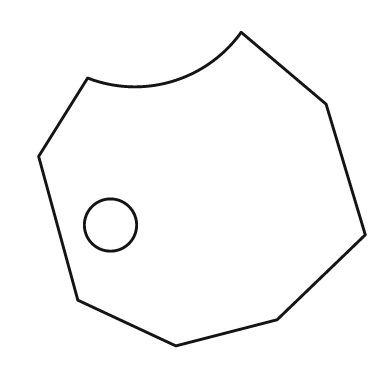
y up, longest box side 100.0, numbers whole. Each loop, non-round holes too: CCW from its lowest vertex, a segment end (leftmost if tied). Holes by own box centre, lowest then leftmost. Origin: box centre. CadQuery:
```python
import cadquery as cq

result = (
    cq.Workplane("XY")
    .moveTo(-8.0, -48.0)
    .lineTo(23.0, -40.0)
    .lineTo(50.0, -14.0)
    .lineTo(38.0, 26.0)
    .lineTo(12.0, 48.0)
    .threePointArc((-9.0, 33.0), (-35.0, 34.0))
    .lineTo(-50.0, 10.0)
    .lineTo(-38.0, -34.0)
    .close()
    .moveTo(-28.0, -11.0)
    .circle(8.0)
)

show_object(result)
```